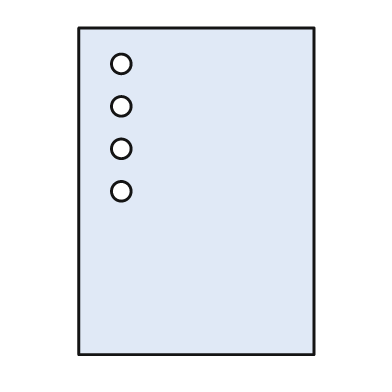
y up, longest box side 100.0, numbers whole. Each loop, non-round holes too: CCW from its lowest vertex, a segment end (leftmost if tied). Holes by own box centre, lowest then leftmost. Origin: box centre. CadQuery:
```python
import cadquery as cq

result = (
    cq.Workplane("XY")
    .moveTo(-36.0, -50.0)
    .lineTo(36.0, -50.0)
    .lineTo(36.0, 50.0)
    .lineTo(-36.0, 50.0)
    .close()
    .moveTo(-23.0, 0.0)
    .circle(3.0)
    .moveTo(-23.0, 13.0)
    .circle(3.0)
    .moveTo(-23.0, 26.0)
    .circle(3.0)
    .moveTo(-23.0, 39.0)
    .circle(3.0)
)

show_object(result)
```